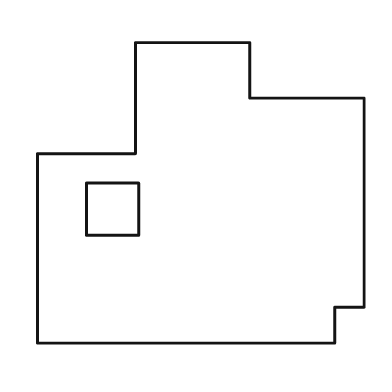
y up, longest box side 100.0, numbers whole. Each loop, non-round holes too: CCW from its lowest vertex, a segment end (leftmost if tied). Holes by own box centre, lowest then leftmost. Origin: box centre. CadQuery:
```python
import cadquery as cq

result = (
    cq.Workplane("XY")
    .moveTo(-50.0, -46.0)
    .lineTo(41.0, -46.0)
    .lineTo(41.0, -35.0)
    .lineTo(50.0, -35.0)
    .lineTo(50.0, 29.0)
    .lineTo(15.0, 29.0)
    .lineTo(15.0, 46.0)
    .lineTo(-20.0, 46.0)
    .lineTo(-20.0, 12.0)
    .lineTo(-50.0, 12.0)
    .close()
    .moveTo(-35.0, -13.0)
    .lineTo(-19.0, -13.0)
    .lineTo(-19.0, 3.0)
    .lineTo(-35.0, 3.0)
    .close()
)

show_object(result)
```